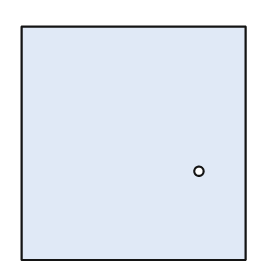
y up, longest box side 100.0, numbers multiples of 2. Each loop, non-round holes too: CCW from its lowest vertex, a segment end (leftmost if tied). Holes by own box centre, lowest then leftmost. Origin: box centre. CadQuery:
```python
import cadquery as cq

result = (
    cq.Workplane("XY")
    .moveTo(-48.0, -50.0)
    .lineTo(48.0, -50.0)
    .lineTo(48.0, 50.0)
    .lineTo(-48.0, 50.0)
    .close()
    .moveTo(28.0, -12.0)
    .circle(2.0)
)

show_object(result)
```